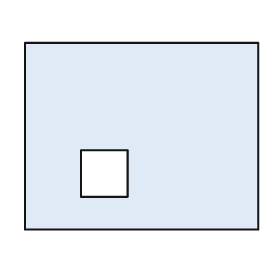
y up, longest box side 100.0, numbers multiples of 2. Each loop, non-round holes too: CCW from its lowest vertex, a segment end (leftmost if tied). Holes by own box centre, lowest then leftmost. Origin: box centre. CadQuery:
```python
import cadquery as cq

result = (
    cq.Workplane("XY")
    .moveTo(-50.0, -40.0)
    .lineTo(50.0, -40.0)
    .lineTo(50.0, 40.0)
    .lineTo(-50.0, 40.0)
    .close()
    .moveTo(-26.0, -26.0)
    .lineTo(-6.0, -26.0)
    .lineTo(-6.0, -6.0)
    .lineTo(-26.0, -6.0)
    .close()
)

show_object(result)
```